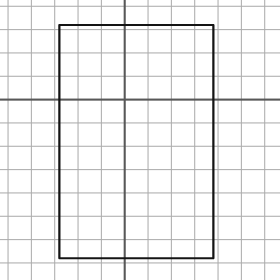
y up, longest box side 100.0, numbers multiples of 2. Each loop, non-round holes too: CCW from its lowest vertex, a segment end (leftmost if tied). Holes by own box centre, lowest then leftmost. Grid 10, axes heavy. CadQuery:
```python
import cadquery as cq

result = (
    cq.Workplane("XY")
    .moveTo(-28.0, -68.0)
    .lineTo(38.0, -68.0)
    .lineTo(38.0, 32.0)
    .lineTo(-28.0, 32.0)
    .close()
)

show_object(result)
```